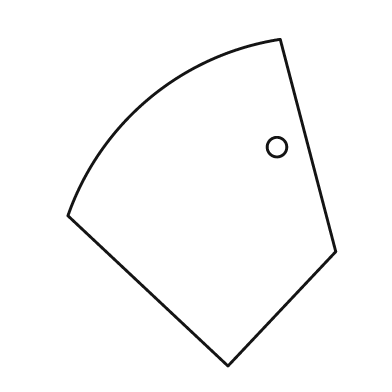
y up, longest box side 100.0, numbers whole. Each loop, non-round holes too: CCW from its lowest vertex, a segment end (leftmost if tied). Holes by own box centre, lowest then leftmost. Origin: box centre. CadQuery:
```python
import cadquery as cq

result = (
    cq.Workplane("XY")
    .moveTo(8.0, -50.0)
    .lineTo(41.0, -15.0)
    .lineTo(24.0, 50.0)
    .threePointArc((-16.0, 32.0), (-41.0, -4.0))
    .close()
    .moveTo(23.0, 17.0)
    .circle(3.0)
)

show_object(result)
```